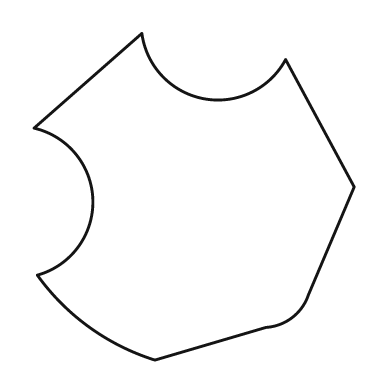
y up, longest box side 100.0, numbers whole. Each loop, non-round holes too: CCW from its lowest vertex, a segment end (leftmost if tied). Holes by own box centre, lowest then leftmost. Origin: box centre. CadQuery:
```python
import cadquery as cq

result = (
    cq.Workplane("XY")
    .moveTo(-12.0, -50.0)
    .lineTo(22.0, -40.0)
    .threePointArc((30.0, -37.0), (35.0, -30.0))
    .lineTo(49.0, 3.0)
    .lineTo(28.0, 42.0)
    .threePointArc((3.0, 30.0), (-16.0, 50.0))
    .lineTo(-49.0, 21.0)
    .threePointArc((-31.0, -1.0), (-48.0, -24.0))
    .threePointArc((-32.0, -40.0), (-12.0, -50.0))
    .close()
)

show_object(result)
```